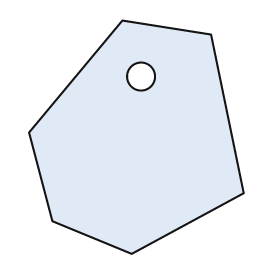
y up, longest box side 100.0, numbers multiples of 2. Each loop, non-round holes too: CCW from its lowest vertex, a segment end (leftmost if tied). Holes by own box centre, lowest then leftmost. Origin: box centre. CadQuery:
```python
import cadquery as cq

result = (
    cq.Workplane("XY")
    .moveTo(-2.0, -50.0)
    .lineTo(46.0, -24.0)
    .lineTo(32.0, 44.0)
    .lineTo(-6.0, 50.0)
    .lineTo(-46.0, 2.0)
    .lineTo(-36.0, -36.0)
    .close()
    .moveTo(2.0, 26.0)
    .circle(6.0)
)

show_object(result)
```